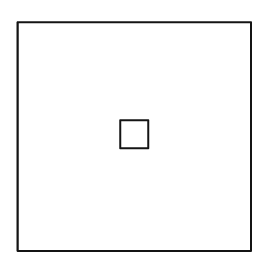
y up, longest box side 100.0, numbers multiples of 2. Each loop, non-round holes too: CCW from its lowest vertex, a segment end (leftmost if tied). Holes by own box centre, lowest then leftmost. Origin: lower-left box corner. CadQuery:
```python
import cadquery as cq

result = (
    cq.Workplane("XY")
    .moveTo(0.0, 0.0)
    .lineTo(100.0, 0.0)
    .lineTo(100.0, 98.0)
    .lineTo(0.0, 98.0)
    .close()
    .moveTo(44.0, 44.0)
    .lineTo(56.0, 44.0)
    .lineTo(56.0, 56.0)
    .lineTo(44.0, 56.0)
    .close()
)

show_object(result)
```